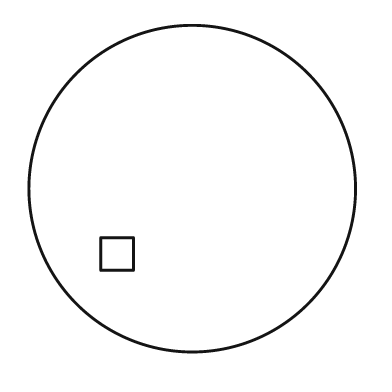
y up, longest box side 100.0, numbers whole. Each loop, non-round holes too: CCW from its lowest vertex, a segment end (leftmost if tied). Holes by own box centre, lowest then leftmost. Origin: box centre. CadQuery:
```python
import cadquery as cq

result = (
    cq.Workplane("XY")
    .moveTo(0.0, 0.0)
    .circle(50.0)
    .moveTo(-28.0, -25.0)
    .lineTo(-18.0, -25.0)
    .lineTo(-18.0, -15.0)
    .lineTo(-28.0, -15.0)
    .close()
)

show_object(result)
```